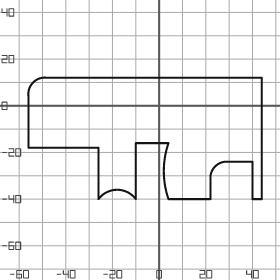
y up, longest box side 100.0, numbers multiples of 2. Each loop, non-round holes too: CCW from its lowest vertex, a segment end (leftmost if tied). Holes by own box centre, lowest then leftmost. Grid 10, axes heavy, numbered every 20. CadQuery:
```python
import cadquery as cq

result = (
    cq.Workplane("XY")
    .moveTo(-26.0, -40.0)
    .threePointArc((-18.0, -36.0), (-10.0, -40.0))
    .lineTo(-10.0, -16.0)
    .lineTo(4.0, -16.0)
    .threePointArc((2.0, -28.0), (4.0, -40.0))
    .lineTo(22.0, -40.0)
    .lineTo(22.0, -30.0)
    .threePointArc((24.0, -26.0), (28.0, -24.0))
    .lineTo(40.0, -24.0)
    .lineTo(40.0, -40.0)
    .lineTo(44.0, -40.0)
    .lineTo(44.0, 12.0)
    .lineTo(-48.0, 12.0)
    .threePointArc((-54.0, 10.0), (-56.0, 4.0))
    .lineTo(-56.0, -18.0)
    .lineTo(-26.0, -18.0)
    .close()
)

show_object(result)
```